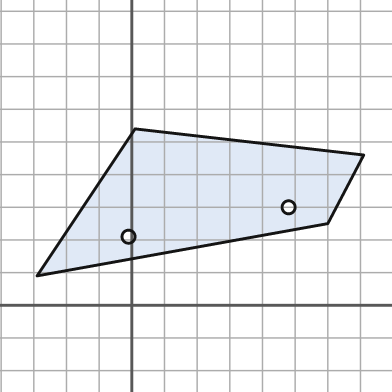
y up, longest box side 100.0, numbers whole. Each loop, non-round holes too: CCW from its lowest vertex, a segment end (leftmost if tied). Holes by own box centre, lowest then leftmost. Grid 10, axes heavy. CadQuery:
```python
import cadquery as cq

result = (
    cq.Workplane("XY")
    .moveTo(-29.0, 9.0)
    .lineTo(60.0, 25.0)
    .lineTo(71.0, 46.0)
    .lineTo(1.0, 54.0)
    .close()
    .moveTo(-1.0, 21.0)
    .circle(2.0)
    .moveTo(48.0, 30.0)
    .circle(2.0)
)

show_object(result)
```